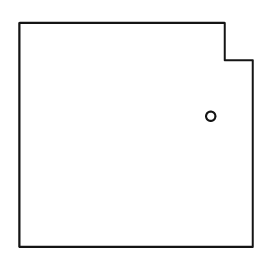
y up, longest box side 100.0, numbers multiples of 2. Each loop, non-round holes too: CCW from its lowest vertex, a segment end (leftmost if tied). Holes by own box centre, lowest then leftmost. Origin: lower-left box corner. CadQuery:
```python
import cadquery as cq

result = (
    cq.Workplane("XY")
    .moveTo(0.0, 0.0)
    .lineTo(100.0, 0.0)
    .lineTo(100.0, 80.0)
    .lineTo(88.0, 80.0)
    .lineTo(88.0, 96.0)
    .lineTo(0.0, 96.0)
    .close()
    .moveTo(82.0, 56.0)
    .circle(2.0)
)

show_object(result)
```